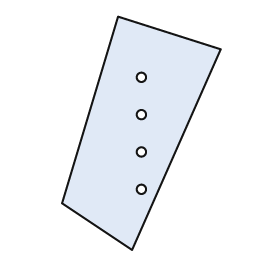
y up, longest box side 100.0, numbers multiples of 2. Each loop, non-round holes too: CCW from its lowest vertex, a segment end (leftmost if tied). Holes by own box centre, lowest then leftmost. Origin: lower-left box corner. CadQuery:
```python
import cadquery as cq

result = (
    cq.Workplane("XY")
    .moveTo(30.0, 0.0)
    .lineTo(68.0, 86.0)
    .lineTo(24.0, 100.0)
    .lineTo(0.0, 20.0)
    .close()
    .moveTo(34.0, 26.0)
    .circle(2.0)
    .moveTo(34.0, 42.0)
    .circle(2.0)
    .moveTo(34.0, 58.0)
    .circle(2.0)
    .moveTo(34.0, 74.0)
    .circle(2.0)
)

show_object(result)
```